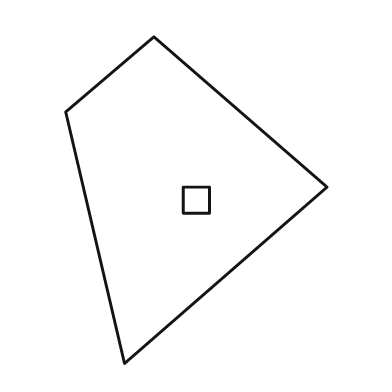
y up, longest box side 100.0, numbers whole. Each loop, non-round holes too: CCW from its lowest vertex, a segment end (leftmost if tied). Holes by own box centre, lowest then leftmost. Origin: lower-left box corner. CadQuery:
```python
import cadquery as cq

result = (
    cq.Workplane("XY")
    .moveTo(18.0, 0.0)
    .lineTo(80.0, 54.0)
    .lineTo(27.0, 100.0)
    .lineTo(0.0, 77.0)
    .close()
    .moveTo(36.0, 46.0)
    .lineTo(44.0, 46.0)
    .lineTo(44.0, 54.0)
    .lineTo(36.0, 54.0)
    .close()
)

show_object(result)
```